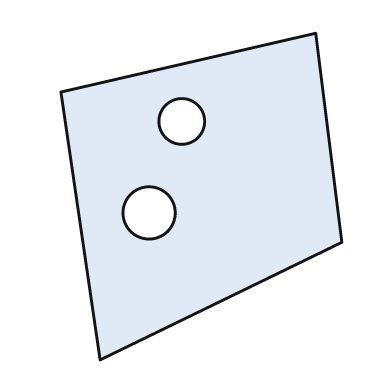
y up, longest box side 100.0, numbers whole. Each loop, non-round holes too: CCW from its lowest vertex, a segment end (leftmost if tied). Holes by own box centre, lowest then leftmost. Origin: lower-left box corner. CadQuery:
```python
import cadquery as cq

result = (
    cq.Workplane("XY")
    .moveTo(12.0, 0.0)
    .lineTo(86.0, 36.0)
    .lineTo(78.0, 100.0)
    .lineTo(0.0, 82.0)
    .close()
    .moveTo(27.0, 45.0)
    .circle(8.0)
    .moveTo(37.0, 73.0)
    .circle(7.0)
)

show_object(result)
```